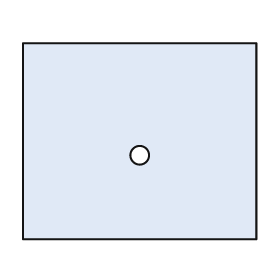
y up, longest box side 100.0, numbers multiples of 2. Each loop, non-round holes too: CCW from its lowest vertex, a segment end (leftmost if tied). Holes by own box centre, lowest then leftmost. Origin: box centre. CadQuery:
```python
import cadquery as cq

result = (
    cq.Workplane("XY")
    .moveTo(-50.0, -42.0)
    .lineTo(50.0, -42.0)
    .lineTo(50.0, 42.0)
    .lineTo(-50.0, 42.0)
    .close()
    .moveTo(0.0, -6.0)
    .circle(4.0)
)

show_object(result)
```